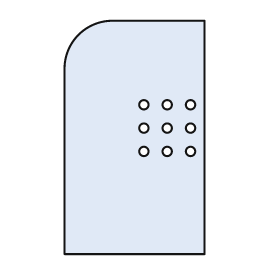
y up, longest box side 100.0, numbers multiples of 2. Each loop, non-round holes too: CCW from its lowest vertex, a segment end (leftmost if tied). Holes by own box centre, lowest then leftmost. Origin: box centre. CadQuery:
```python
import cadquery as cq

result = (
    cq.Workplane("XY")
    .moveTo(-30.0, -50.0)
    .lineTo(30.0, -50.0)
    .lineTo(30.0, 50.0)
    .lineTo(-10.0, 50.0)
    .threePointArc((-24.0, 44.0), (-30.0, 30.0))
    .close()
    .moveTo(4.0, -6.0)
    .circle(2.0)
    .moveTo(14.0, -6.0)
    .circle(2.0)
    .moveTo(24.0, -6.0)
    .circle(2.0)
    .moveTo(4.0, 4.0)
    .circle(2.0)
    .moveTo(14.0, 4.0)
    .circle(2.0)
    .moveTo(24.0, 4.0)
    .circle(2.0)
    .moveTo(4.0, 14.0)
    .circle(2.0)
    .moveTo(14.0, 14.0)
    .circle(2.0)
    .moveTo(24.0, 14.0)
    .circle(2.0)
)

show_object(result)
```